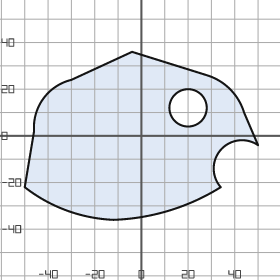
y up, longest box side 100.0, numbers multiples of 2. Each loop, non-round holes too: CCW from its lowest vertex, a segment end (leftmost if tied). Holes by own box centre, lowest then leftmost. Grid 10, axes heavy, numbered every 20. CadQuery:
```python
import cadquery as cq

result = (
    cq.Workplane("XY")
    .moveTo(-12.0, -36.0)
    .threePointArc((12.0, -32.0), (34.0, -22.0))
    .threePointArc((34.0, -6.0), (50.0, -4.0))
    .lineTo(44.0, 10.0)
    .threePointArc((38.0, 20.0), (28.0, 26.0))
    .lineTo(-4.0, 36.0)
    .lineTo(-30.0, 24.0)
    .threePointArc((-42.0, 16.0), (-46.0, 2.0))
    .lineTo(-50.0, -22.0)
    .threePointArc((-32.0, -32.0), (-12.0, -36.0))
    .close()
    .moveTo(20.0, 12.0)
    .circle(8.0)
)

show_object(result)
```